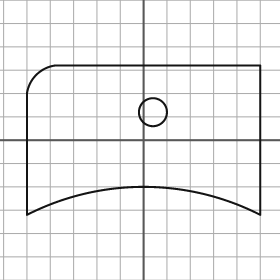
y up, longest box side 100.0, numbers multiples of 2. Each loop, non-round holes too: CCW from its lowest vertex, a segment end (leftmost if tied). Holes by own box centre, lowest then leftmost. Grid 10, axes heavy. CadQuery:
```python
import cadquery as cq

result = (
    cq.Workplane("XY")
    .moveTo(-50.0, -32.0)
    .threePointArc((0.0, -20.0), (50.0, -32.0))
    .lineTo(50.0, 32.0)
    .lineTo(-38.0, 32.0)
    .threePointArc((-46.0, 28.0), (-50.0, 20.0))
    .close()
    .moveTo(4.0, 12.0)
    .circle(6.0)
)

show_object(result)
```